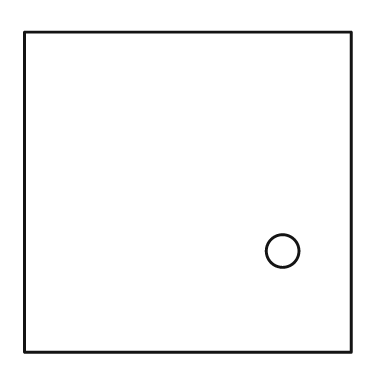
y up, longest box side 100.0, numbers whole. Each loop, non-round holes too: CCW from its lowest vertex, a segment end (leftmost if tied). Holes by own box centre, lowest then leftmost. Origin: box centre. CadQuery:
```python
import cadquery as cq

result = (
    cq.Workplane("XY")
    .moveTo(-50.0, -49.0)
    .lineTo(50.0, -49.0)
    .lineTo(50.0, 49.0)
    .lineTo(-50.0, 49.0)
    .close()
    .moveTo(29.0, -18.0)
    .circle(5.0)
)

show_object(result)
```